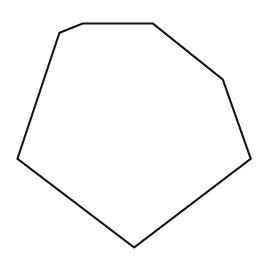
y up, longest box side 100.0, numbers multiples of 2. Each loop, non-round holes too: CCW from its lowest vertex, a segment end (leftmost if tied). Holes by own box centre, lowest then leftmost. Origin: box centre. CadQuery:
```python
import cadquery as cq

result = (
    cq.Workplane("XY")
    .moveTo(0.0, -48.0)
    .lineTo(50.0, -10.0)
    .lineTo(38.0, 24.0)
    .lineTo(8.0, 48.0)
    .lineTo(-22.0, 48.0)
    .lineTo(-32.0, 44.0)
    .lineTo(-50.0, -10.0)
    .close()
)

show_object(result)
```